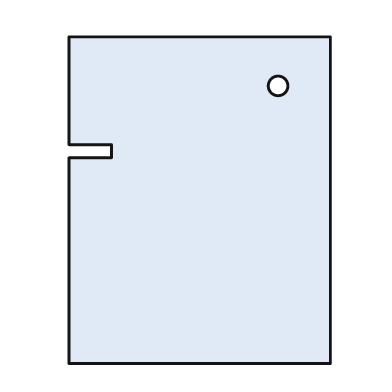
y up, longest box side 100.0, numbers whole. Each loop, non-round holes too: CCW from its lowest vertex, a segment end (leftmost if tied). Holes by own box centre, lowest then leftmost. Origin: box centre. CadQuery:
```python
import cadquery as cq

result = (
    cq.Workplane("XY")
    .moveTo(-40.0, -50.0)
    .lineTo(40.0, -50.0)
    .lineTo(40.0, 50.0)
    .lineTo(-40.0, 50.0)
    .lineTo(-40.0, 17.0)
    .lineTo(-27.0, 17.0)
    .lineTo(-27.0, 13.0)
    .lineTo(-40.0, 13.0)
    .close()
    .moveTo(24.0, 35.0)
    .circle(3.0)
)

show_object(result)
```